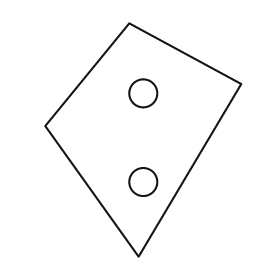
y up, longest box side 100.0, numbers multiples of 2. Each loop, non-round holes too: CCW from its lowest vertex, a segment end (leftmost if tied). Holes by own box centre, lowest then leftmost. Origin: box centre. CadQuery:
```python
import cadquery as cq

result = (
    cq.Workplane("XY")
    .moveTo(-2.0, -50.0)
    .lineTo(42.0, 24.0)
    .lineTo(-6.0, 50.0)
    .lineTo(-42.0, 6.0)
    .close()
    .moveTo(0.0, -18.0)
    .circle(6.0)
    .moveTo(0.0, 20.0)
    .circle(6.0)
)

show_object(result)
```